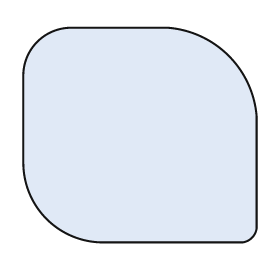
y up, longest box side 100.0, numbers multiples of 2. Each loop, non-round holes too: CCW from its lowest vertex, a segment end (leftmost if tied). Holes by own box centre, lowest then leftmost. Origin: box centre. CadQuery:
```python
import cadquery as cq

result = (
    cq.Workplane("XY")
    .moveTo(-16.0, -46.0)
    .lineTo(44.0, -46.0)
    .threePointArc((48.0, -44.0), (50.0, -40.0))
    .lineTo(50.0, 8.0)
    .threePointArc((38.0, 34.0), (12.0, 46.0))
    .lineTo(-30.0, 46.0)
    .threePointArc((-44.0, 40.0), (-50.0, 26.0))
    .lineTo(-50.0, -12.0)
    .threePointArc((-40.0, -36.0), (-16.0, -46.0))
    .close()
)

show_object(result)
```